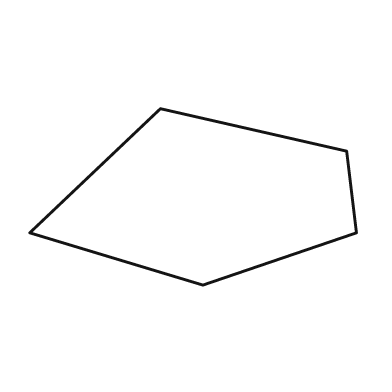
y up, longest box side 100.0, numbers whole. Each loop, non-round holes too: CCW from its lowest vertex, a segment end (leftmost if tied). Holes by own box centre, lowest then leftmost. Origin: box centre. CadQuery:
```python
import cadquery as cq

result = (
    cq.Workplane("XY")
    .moveTo(3.0, -27.0)
    .lineTo(50.0, -11.0)
    .lineTo(47.0, 14.0)
    .lineTo(-10.0, 27.0)
    .lineTo(-50.0, -11.0)
    .close()
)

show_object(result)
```